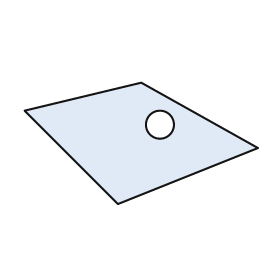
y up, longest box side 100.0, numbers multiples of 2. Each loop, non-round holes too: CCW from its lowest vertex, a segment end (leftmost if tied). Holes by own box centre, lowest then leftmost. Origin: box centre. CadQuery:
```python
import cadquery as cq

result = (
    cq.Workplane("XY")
    .moveTo(-10.0, -26.0)
    .lineTo(50.0, -2.0)
    .lineTo(0.0, 26.0)
    .lineTo(-50.0, 14.0)
    .close()
    .moveTo(8.0, 8.0)
    .circle(6.0)
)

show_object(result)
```